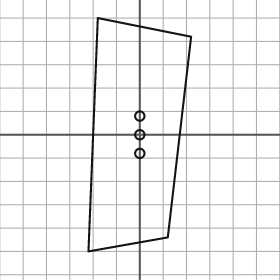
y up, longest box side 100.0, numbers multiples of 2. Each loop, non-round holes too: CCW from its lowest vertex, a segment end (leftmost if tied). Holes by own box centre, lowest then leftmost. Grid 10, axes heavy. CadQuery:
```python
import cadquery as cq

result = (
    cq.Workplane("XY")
    .moveTo(-22.0, -50.0)
    .lineTo(12.0, -44.0)
    .lineTo(22.0, 42.0)
    .lineTo(-18.0, 50.0)
    .close()
    .moveTo(0.0, -8.0)
    .circle(2.0)
    .moveTo(0.0, 0.0)
    .circle(2.0)
    .moveTo(0.0, 8.0)
    .circle(2.0)
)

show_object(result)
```